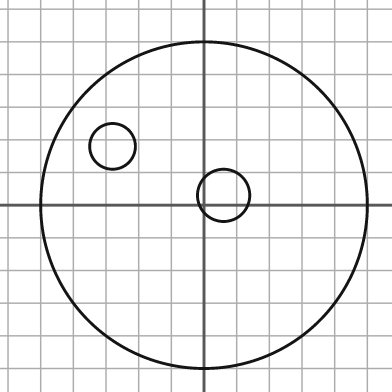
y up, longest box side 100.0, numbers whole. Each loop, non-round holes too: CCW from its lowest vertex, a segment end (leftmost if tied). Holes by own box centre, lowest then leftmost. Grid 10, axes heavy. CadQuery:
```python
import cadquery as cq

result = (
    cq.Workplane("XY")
    .moveTo(0.0, 0.0)
    .circle(50.0)
    .moveTo(6.0, 3.0)
    .circle(8.0)
    .moveTo(-28.0, 18.0)
    .circle(7.0)
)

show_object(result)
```